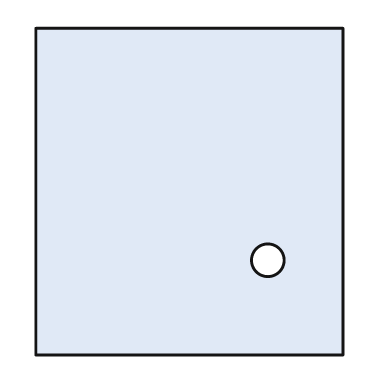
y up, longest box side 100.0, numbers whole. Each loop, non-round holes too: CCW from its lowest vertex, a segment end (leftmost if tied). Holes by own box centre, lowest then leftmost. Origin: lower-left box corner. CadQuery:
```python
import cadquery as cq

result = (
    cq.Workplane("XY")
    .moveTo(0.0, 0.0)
    .lineTo(94.0, 0.0)
    .lineTo(94.0, 100.0)
    .lineTo(0.0, 100.0)
    .close()
    .moveTo(71.0, 29.0)
    .circle(5.0)
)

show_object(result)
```